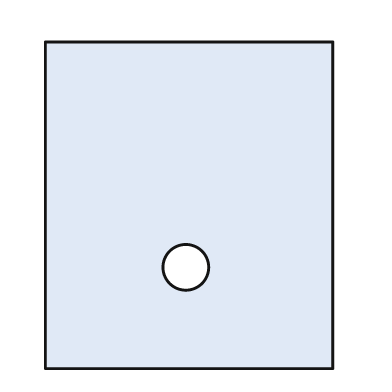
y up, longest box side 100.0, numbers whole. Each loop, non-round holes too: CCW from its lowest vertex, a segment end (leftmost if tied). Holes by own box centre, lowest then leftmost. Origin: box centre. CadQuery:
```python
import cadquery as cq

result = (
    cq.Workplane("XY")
    .moveTo(-44.0, -50.0)
    .lineTo(44.0, -50.0)
    .lineTo(44.0, 50.0)
    .lineTo(-44.0, 50.0)
    .close()
    .moveTo(-1.0, -19.0)
    .circle(7.0)
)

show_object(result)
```